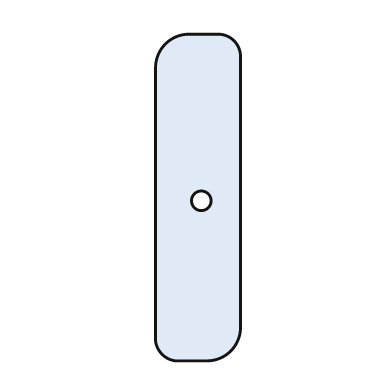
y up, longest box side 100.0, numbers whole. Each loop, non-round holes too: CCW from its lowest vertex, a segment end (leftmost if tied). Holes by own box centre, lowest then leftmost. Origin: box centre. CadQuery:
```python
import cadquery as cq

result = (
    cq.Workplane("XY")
    .moveTo(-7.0, -50.0)
    .lineTo(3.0, -50.0)
    .threePointArc((10.0, -47.0), (13.0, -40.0))
    .lineTo(13.0, 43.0)
    .threePointArc((11.0, 48.0), (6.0, 50.0))
    .lineTo(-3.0, 50.0)
    .threePointArc((-10.0, 47.0), (-13.0, 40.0))
    .lineTo(-13.0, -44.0)
    .threePointArc((-11.0, -48.0), (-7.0, -50.0))
    .close()
    .moveTo(1.0, -1.0)
    .circle(3.0)
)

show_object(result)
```